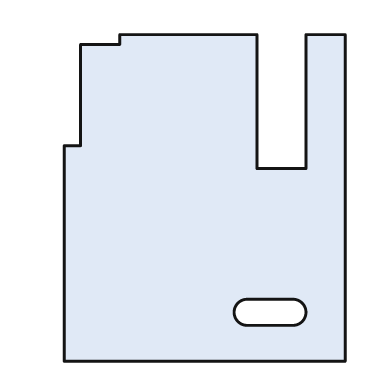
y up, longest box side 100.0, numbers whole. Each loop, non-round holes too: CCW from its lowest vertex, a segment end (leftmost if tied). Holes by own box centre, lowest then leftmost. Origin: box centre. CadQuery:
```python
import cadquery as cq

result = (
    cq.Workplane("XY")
    .moveTo(-43.0, -50.0)
    .lineTo(43.0, -50.0)
    .lineTo(43.0, 50.0)
    .lineTo(31.0, 50.0)
    .lineTo(31.0, 9.0)
    .lineTo(16.0, 9.0)
    .lineTo(16.0, 50.0)
    .lineTo(-26.0, 50.0)
    .lineTo(-26.0, 47.0)
    .lineTo(-38.0, 47.0)
    .lineTo(-38.0, 16.0)
    .lineTo(-43.0, 16.0)
    .close()
    .moveTo(13.0, -39.0)
    .lineTo(27.0, -39.0)
    .threePointArc((31.0, -35.0), (27.0, -31.0))
    .lineTo(13.0, -31.0)
    .threePointArc((9.0, -35.0), (13.0, -39.0))
    .close()
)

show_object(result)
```